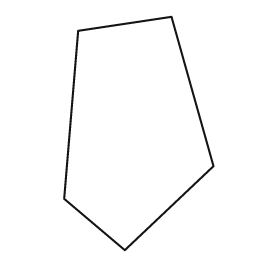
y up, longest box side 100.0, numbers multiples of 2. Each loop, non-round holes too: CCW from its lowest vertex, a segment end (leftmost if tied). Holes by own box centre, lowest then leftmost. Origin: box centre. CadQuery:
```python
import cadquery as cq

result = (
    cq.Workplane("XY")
    .moveTo(-6.0, -50.0)
    .lineTo(32.0, -14.0)
    .lineTo(14.0, 50.0)
    .lineTo(-26.0, 44.0)
    .lineTo(-32.0, -28.0)
    .close()
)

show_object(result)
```